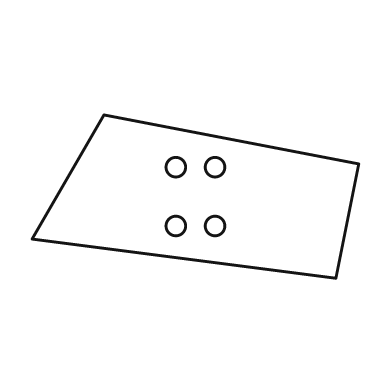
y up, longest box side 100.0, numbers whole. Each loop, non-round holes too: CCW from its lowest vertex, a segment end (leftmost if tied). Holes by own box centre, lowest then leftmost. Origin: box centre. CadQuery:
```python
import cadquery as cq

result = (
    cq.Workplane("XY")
    .moveTo(43.0, -25.0)
    .lineTo(50.0, 10.0)
    .lineTo(-28.0, 25.0)
    .lineTo(-50.0, -13.0)
    .close()
    .moveTo(-6.0, -9.0)
    .circle(3.0)
    .moveTo(6.0, -9.0)
    .circle(3.0)
    .moveTo(-6.0, 9.0)
    .circle(3.0)
    .moveTo(6.0, 9.0)
    .circle(3.0)
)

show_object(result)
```